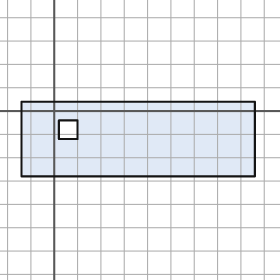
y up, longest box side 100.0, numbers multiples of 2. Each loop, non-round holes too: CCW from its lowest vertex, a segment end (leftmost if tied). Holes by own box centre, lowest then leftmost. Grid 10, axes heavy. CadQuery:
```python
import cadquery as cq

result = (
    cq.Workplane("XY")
    .moveTo(-14.0, -28.0)
    .lineTo(86.0, -28.0)
    .lineTo(86.0, 4.0)
    .lineTo(-14.0, 4.0)
    .close()
    .moveTo(2.0, -12.0)
    .lineTo(10.0, -12.0)
    .lineTo(10.0, -4.0)
    .lineTo(2.0, -4.0)
    .close()
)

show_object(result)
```